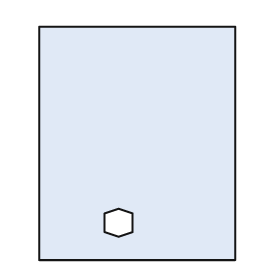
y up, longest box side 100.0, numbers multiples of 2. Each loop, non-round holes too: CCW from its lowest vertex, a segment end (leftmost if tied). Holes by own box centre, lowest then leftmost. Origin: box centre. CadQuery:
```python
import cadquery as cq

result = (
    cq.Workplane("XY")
    .moveTo(-42.0, -50.0)
    .lineTo(42.0, -50.0)
    .lineTo(42.0, 50.0)
    .lineTo(-42.0, 50.0)
    .close()
    .moveTo(-8.0, -40.0)
    .lineTo(-2.0, -38.0)
    .lineTo(-2.0, -30.0)
    .lineTo(-8.0, -28.0)
    .lineTo(-14.0, -30.0)
    .lineTo(-14.0, -38.0)
    .close()
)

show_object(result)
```